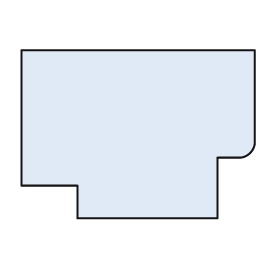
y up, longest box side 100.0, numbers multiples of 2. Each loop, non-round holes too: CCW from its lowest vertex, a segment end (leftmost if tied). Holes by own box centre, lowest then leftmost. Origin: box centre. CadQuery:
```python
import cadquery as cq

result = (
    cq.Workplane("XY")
    .moveTo(-26.0, -36.0)
    .lineTo(34.0, -36.0)
    .lineTo(34.0, -10.0)
    .lineTo(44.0, -10.0)
    .threePointArc((48.0, -8.0), (50.0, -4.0))
    .lineTo(50.0, 36.0)
    .lineTo(-50.0, 36.0)
    .lineTo(-50.0, -22.0)
    .lineTo(-26.0, -22.0)
    .close()
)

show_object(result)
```